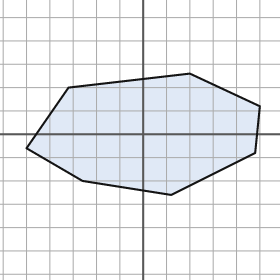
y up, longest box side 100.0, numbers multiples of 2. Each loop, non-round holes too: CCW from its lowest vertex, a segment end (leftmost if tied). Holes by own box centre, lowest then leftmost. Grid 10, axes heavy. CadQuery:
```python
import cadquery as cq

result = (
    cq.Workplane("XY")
    .moveTo(12.0, -26.0)
    .lineTo(48.0, -8.0)
    .lineTo(50.0, 12.0)
    .lineTo(20.0, 26.0)
    .lineTo(-32.0, 20.0)
    .lineTo(-50.0, -6.0)
    .lineTo(-26.0, -20.0)
    .close()
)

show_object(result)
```